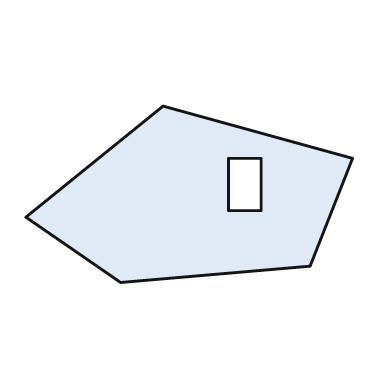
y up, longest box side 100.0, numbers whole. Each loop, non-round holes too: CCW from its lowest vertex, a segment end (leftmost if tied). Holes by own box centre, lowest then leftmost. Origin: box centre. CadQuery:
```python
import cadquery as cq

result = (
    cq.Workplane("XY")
    .moveTo(-21.0, -27.0)
    .lineTo(37.0, -22.0)
    .lineTo(50.0, 11.0)
    .lineTo(-8.0, 27.0)
    .lineTo(-50.0, -7.0)
    .close()
    .moveTo(12.0, -5.0)
    .lineTo(22.0, -5.0)
    .lineTo(22.0, 11.0)
    .lineTo(12.0, 11.0)
    .close()
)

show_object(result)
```